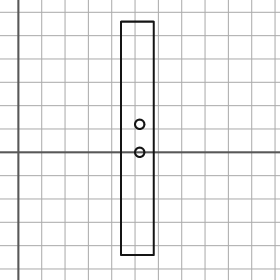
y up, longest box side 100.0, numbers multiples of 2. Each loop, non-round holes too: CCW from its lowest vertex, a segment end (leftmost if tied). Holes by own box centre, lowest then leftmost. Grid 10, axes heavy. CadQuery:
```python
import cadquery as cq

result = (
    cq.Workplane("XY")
    .moveTo(44.0, -44.0)
    .lineTo(58.0, -44.0)
    .lineTo(58.0, 56.0)
    .lineTo(44.0, 56.0)
    .close()
    .moveTo(52.0, 0.0)
    .circle(2.0)
    .moveTo(52.0, 12.0)
    .circle(2.0)
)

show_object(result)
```